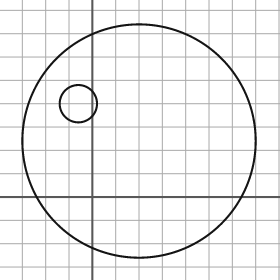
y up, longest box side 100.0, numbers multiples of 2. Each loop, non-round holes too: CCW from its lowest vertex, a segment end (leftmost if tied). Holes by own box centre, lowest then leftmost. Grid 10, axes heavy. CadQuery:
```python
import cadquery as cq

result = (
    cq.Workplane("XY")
    .moveTo(20.0, 24.0)
    .circle(50.0)
    .moveTo(-6.0, 40.0)
    .circle(8.0)
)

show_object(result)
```